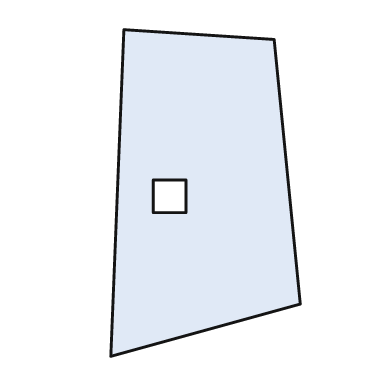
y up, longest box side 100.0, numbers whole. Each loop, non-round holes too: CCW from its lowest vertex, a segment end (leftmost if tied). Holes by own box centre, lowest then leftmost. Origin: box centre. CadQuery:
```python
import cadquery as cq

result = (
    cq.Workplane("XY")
    .moveTo(-29.0, -50.0)
    .lineTo(29.0, -34.0)
    .lineTo(21.0, 47.0)
    .lineTo(-25.0, 50.0)
    .close()
    .moveTo(-16.0, -6.0)
    .lineTo(-6.0, -6.0)
    .lineTo(-6.0, 4.0)
    .lineTo(-16.0, 4.0)
    .close()
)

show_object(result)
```